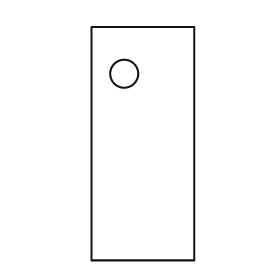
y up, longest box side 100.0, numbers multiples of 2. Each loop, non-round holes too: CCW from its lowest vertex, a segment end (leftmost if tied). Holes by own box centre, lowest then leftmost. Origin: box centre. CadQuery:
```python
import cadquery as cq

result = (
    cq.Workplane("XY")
    .moveTo(-22.0, -50.0)
    .lineTo(22.0, -50.0)
    .lineTo(22.0, 50.0)
    .lineTo(-22.0, 50.0)
    .close()
    .moveTo(-8.0, 30.0)
    .circle(6.0)
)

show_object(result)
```